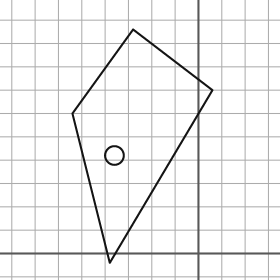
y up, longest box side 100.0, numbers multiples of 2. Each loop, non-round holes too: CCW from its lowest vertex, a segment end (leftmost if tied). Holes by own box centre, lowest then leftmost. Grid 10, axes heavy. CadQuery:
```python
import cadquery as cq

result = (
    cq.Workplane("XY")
    .moveTo(-38.0, -4.0)
    .lineTo(6.0, 70.0)
    .lineTo(-28.0, 96.0)
    .lineTo(-54.0, 60.0)
    .close()
    .moveTo(-36.0, 42.0)
    .circle(4.0)
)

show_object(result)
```